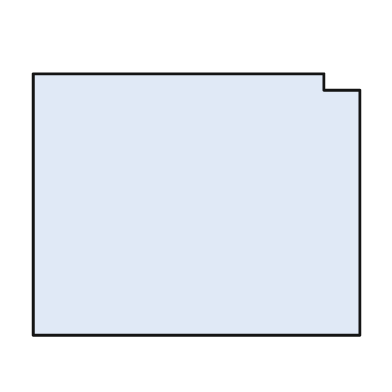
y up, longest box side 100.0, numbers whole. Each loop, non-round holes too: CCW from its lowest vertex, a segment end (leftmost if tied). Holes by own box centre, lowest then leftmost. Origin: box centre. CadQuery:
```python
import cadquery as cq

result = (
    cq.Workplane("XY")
    .moveTo(-50.0, -40.0)
    .lineTo(50.0, -40.0)
    .lineTo(50.0, 35.0)
    .lineTo(39.0, 35.0)
    .lineTo(39.0, 40.0)
    .lineTo(-50.0, 40.0)
    .close()
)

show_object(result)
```